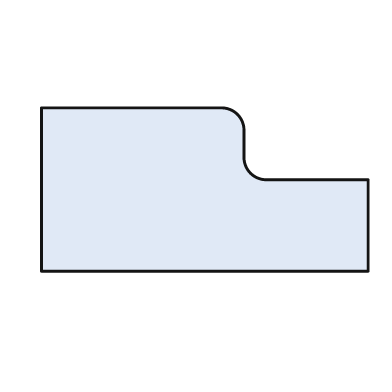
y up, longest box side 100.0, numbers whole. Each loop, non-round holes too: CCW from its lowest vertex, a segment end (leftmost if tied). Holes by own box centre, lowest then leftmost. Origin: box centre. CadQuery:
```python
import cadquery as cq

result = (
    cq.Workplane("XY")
    .moveTo(-50.0, -25.0)
    .lineTo(50.0, -25.0)
    .lineTo(50.0, 3.0)
    .lineTo(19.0, 3.0)
    .threePointArc((14.0, 5.0), (12.0, 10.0))
    .lineTo(12.0, 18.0)
    .threePointArc((10.0, 23.0), (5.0, 25.0))
    .lineTo(-50.0, 25.0)
    .close()
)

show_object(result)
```